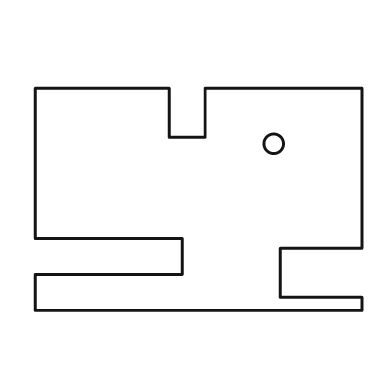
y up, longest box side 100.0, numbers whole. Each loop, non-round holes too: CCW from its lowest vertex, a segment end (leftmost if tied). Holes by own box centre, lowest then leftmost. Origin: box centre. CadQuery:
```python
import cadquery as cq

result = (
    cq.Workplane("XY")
    .moveTo(-50.0, -34.0)
    .lineTo(50.0, -34.0)
    .lineTo(50.0, -30.0)
    .lineTo(25.0, -30.0)
    .lineTo(25.0, -15.0)
    .lineTo(50.0, -15.0)
    .lineTo(50.0, 34.0)
    .lineTo(2.0, 34.0)
    .lineTo(2.0, 19.0)
    .lineTo(-9.0, 19.0)
    .lineTo(-9.0, 34.0)
    .lineTo(-50.0, 34.0)
    .lineTo(-50.0, -12.0)
    .lineTo(-5.0, -12.0)
    .lineTo(-5.0, -23.0)
    .lineTo(-50.0, -23.0)
    .close()
    .moveTo(23.0, 17.0)
    .circle(3.0)
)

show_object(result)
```